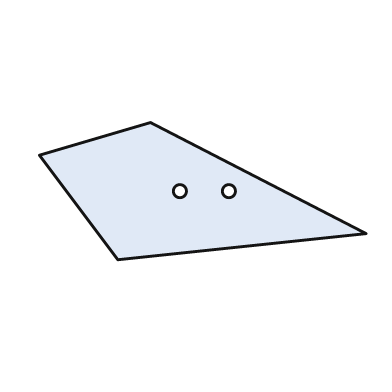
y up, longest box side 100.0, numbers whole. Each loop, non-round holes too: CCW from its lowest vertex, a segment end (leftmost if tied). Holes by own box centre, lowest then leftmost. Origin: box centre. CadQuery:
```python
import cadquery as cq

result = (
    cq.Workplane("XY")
    .moveTo(-26.0, -21.0)
    .lineTo(50.0, -13.0)
    .lineTo(-16.0, 21.0)
    .lineTo(-50.0, 11.0)
    .close()
    .moveTo(-7.0, 0.0)
    .circle(2.0)
    .moveTo(8.0, 0.0)
    .circle(2.0)
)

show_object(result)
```